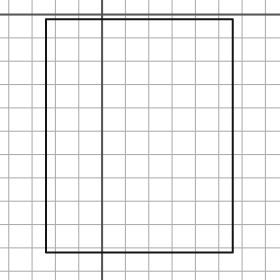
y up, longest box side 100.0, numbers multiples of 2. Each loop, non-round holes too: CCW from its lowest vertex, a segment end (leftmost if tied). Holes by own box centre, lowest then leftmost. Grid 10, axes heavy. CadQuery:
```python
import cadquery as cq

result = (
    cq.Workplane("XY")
    .moveTo(-24.0, -102.0)
    .lineTo(56.0, -102.0)
    .lineTo(56.0, -2.0)
    .lineTo(-24.0, -2.0)
    .close()
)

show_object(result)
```